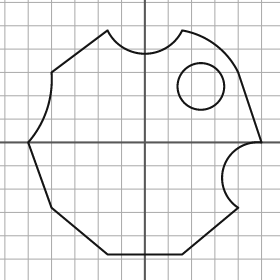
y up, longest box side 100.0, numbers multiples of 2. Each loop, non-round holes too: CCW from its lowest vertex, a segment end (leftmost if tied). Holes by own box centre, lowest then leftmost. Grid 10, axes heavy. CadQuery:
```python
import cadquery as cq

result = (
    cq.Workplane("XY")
    .moveTo(-16.0, -48.0)
    .lineTo(16.0, -48.0)
    .lineTo(40.0, -28.0)
    .threePointArc((34.0, -10.0), (50.0, 0.0))
    .lineTo(40.0, 30.0)
    .threePointArc((30.0, 42.0), (16.0, 48.0))
    .threePointArc((0.0, 38.0), (-16.0, 48.0))
    .lineTo(-40.0, 30.0)
    .threePointArc((-42.0, 14.0), (-50.0, 0.0))
    .lineTo(-40.0, -28.0)
    .close()
    .moveTo(24.0, 24.0)
    .circle(10.0)
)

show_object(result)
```